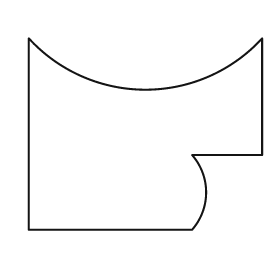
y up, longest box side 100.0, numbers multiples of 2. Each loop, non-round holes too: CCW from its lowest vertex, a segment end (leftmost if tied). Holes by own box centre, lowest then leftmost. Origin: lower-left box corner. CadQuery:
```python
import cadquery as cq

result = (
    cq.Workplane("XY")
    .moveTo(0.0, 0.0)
    .lineTo(70.0, 0.0)
    .threePointArc((76.0, 16.0), (70.0, 32.0))
    .lineTo(100.0, 32.0)
    .lineTo(100.0, 82.0)
    .threePointArc((50.0, 60.0), (0.0, 82.0))
    .close()
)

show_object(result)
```